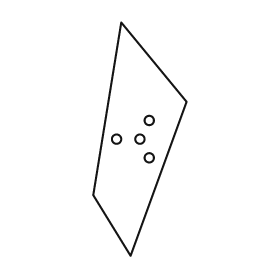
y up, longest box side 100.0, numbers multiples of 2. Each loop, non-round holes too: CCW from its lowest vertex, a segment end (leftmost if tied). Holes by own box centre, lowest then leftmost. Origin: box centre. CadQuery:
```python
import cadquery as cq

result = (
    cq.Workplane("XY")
    .moveTo(-4.0, -50.0)
    .lineTo(20.0, 16.0)
    .lineTo(-8.0, 50.0)
    .lineTo(-20.0, -24.0)
    .close()
    .moveTo(4.0, -8.0)
    .circle(2.0)
    .moveTo(-10.0, 0.0)
    .circle(2.0)
    .moveTo(0.0, 0.0)
    .circle(2.0)
    .moveTo(4.0, 8.0)
    .circle(2.0)
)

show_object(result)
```